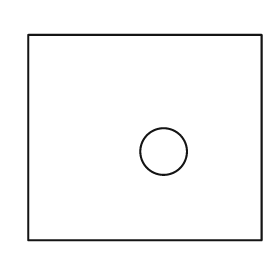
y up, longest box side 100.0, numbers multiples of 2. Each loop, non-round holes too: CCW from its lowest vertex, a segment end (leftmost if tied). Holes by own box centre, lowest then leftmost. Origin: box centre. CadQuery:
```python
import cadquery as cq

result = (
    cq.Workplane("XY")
    .moveTo(-50.0, -44.0)
    .lineTo(50.0, -44.0)
    .lineTo(50.0, 44.0)
    .lineTo(-50.0, 44.0)
    .close()
    .moveTo(8.0, -6.0)
    .circle(10.0)
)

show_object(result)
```